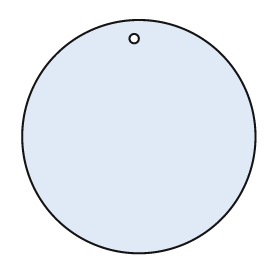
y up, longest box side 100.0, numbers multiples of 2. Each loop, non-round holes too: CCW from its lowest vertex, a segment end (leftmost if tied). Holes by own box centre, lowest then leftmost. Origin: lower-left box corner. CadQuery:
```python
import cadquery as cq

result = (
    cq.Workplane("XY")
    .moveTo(50.0, 50.0)
    .circle(50.0)
    .moveTo(48.0, 92.0)
    .circle(2.0)
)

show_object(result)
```